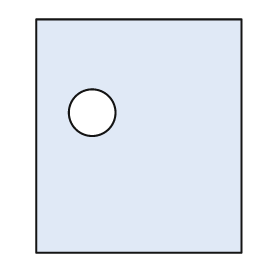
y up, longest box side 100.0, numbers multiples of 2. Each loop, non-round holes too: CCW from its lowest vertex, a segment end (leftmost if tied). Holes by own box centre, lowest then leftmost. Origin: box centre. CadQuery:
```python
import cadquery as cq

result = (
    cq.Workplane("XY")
    .moveTo(-44.0, -50.0)
    .lineTo(44.0, -50.0)
    .lineTo(44.0, 50.0)
    .lineTo(-44.0, 50.0)
    .close()
    .moveTo(-20.0, 10.0)
    .circle(10.0)
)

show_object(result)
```